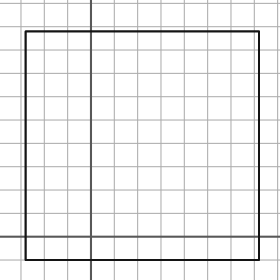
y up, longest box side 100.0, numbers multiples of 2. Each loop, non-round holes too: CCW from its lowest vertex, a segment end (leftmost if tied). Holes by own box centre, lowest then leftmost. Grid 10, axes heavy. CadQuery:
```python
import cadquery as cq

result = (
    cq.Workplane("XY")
    .moveTo(-28.0, -10.0)
    .lineTo(72.0, -10.0)
    .lineTo(72.0, 88.0)
    .lineTo(-28.0, 88.0)
    .close()
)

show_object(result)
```